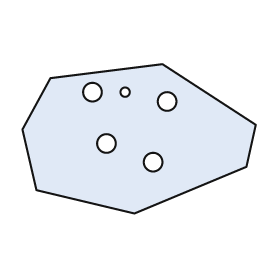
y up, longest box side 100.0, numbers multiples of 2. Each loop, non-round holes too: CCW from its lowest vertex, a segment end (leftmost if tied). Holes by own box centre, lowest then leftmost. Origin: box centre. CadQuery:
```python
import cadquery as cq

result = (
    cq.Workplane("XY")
    .moveTo(-2.0, -32.0)
    .lineTo(46.0, -12.0)
    .lineTo(50.0, 6.0)
    .lineTo(10.0, 32.0)
    .lineTo(-38.0, 26.0)
    .lineTo(-50.0, 4.0)
    .lineTo(-44.0, -22.0)
    .close()
    .moveTo(6.0, -10.0)
    .circle(4.0)
    .moveTo(-14.0, -2.0)
    .circle(4.0)
    .moveTo(12.0, 16.0)
    .circle(4.0)
    .moveTo(-20.0, 20.0)
    .circle(4.0)
    .moveTo(-6.0, 20.0)
    .circle(2.0)
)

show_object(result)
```